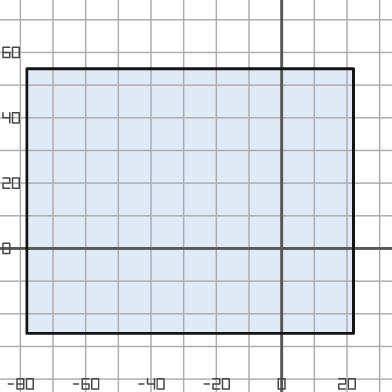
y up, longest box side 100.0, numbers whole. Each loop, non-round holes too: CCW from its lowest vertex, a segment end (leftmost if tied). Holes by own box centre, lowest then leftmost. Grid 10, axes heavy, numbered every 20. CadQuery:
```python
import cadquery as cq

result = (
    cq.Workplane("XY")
    .moveTo(-78.0, -26.0)
    .lineTo(22.0, -26.0)
    .lineTo(22.0, 55.0)
    .lineTo(-78.0, 55.0)
    .close()
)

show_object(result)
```